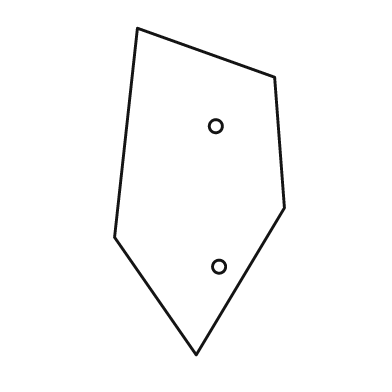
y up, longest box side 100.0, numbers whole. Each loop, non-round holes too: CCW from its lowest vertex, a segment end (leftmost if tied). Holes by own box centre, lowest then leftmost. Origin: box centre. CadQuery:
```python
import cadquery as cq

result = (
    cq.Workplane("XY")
    .moveTo(-1.0, -50.0)
    .lineTo(26.0, -5.0)
    .lineTo(23.0, 35.0)
    .lineTo(-19.0, 50.0)
    .lineTo(-26.0, -14.0)
    .close()
    .moveTo(6.0, -23.0)
    .circle(2.0)
    .moveTo(5.0, 20.0)
    .circle(2.0)
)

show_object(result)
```